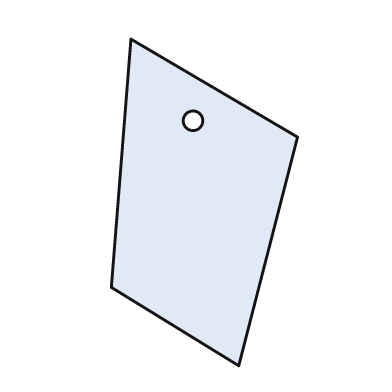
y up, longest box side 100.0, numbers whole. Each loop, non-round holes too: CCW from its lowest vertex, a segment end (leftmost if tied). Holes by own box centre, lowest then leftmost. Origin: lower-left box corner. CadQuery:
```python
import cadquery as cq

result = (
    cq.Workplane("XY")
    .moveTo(39.0, 0.0)
    .lineTo(57.0, 70.0)
    .lineTo(6.0, 100.0)
    .lineTo(0.0, 24.0)
    .close()
    .moveTo(25.0, 75.0)
    .circle(3.0)
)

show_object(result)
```